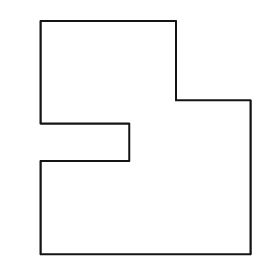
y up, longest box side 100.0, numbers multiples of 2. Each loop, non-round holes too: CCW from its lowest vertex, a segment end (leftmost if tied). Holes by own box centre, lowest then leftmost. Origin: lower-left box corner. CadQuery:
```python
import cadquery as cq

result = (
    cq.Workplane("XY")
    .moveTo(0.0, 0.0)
    .lineTo(90.0, 0.0)
    .lineTo(90.0, 66.0)
    .lineTo(58.0, 66.0)
    .lineTo(58.0, 100.0)
    .lineTo(0.0, 100.0)
    .lineTo(0.0, 56.0)
    .lineTo(38.0, 56.0)
    .lineTo(38.0, 40.0)
    .lineTo(0.0, 40.0)
    .close()
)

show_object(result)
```